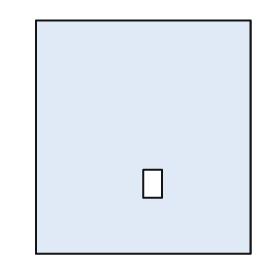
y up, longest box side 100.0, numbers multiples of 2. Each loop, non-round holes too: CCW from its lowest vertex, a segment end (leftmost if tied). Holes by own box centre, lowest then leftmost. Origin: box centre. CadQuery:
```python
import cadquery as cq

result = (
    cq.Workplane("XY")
    .moveTo(-46.0, -50.0)
    .lineTo(46.0, -50.0)
    .lineTo(46.0, 50.0)
    .lineTo(-46.0, 50.0)
    .close()
    .moveTo(0.0, -26.0)
    .lineTo(8.0, -26.0)
    .lineTo(8.0, -14.0)
    .lineTo(0.0, -14.0)
    .close()
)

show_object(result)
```